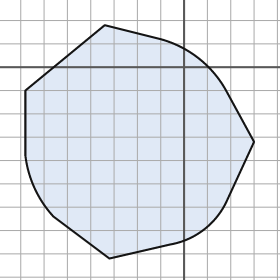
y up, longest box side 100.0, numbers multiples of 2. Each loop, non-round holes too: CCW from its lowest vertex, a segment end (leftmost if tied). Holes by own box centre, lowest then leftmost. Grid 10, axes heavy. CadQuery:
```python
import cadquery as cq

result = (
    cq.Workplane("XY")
    .moveTo(-32.0, -82.0)
    .lineTo(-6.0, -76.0)
    .threePointArc((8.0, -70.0), (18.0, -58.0))
    .lineTo(30.0, -32.0)
    .lineTo(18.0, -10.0)
    .threePointArc((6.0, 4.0), (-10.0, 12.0))
    .lineTo(-34.0, 18.0)
    .lineTo(-68.0, -10.0)
    .lineTo(-68.0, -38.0)
    .threePointArc((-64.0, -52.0), (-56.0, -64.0))
    .close()
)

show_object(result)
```